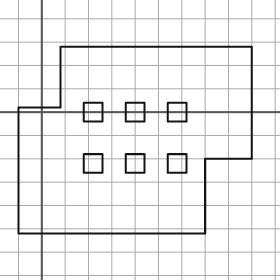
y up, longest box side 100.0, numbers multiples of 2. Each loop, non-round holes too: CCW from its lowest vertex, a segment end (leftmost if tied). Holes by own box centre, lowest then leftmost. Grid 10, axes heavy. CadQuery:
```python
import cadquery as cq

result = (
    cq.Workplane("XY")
    .moveTo(-10.0, -52.0)
    .lineTo(70.0, -52.0)
    .lineTo(70.0, -20.0)
    .lineTo(90.0, -20.0)
    .lineTo(90.0, 28.0)
    .lineTo(8.0, 28.0)
    .lineTo(8.0, 2.0)
    .lineTo(-10.0, 2.0)
    .close()
    .moveTo(18.0, -26.0)
    .lineTo(26.0, -26.0)
    .lineTo(26.0, -18.0)
    .lineTo(18.0, -18.0)
    .close()
    .moveTo(36.0, -26.0)
    .lineTo(44.0, -26.0)
    .lineTo(44.0, -18.0)
    .lineTo(36.0, -18.0)
    .close()
    .moveTo(54.0, -26.0)
    .lineTo(62.0, -26.0)
    .lineTo(62.0, -18.0)
    .lineTo(54.0, -18.0)
    .close()
    .moveTo(18.0, -4.0)
    .lineTo(26.0, -4.0)
    .lineTo(26.0, 4.0)
    .lineTo(18.0, 4.0)
    .close()
    .moveTo(36.0, -4.0)
    .lineTo(44.0, -4.0)
    .lineTo(44.0, 4.0)
    .lineTo(36.0, 4.0)
    .close()
    .moveTo(54.0, -4.0)
    .lineTo(62.0, -4.0)
    .lineTo(62.0, 4.0)
    .lineTo(54.0, 4.0)
    .close()
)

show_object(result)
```